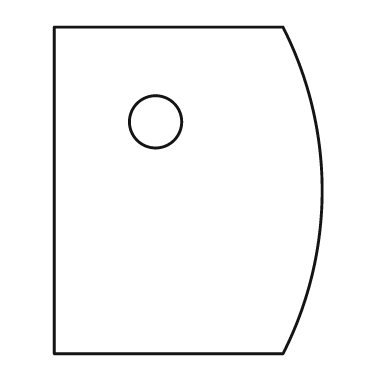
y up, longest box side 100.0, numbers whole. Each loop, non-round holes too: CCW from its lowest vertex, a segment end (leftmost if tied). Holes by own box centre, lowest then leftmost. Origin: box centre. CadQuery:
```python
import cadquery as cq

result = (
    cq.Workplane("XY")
    .moveTo(-41.0, -50.0)
    .lineTo(29.0, -50.0)
    .threePointArc((41.0, 0.0), (29.0, 50.0))
    .lineTo(-41.0, 50.0)
    .close()
    .moveTo(-10.0, 21.0)
    .circle(8.0)
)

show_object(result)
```